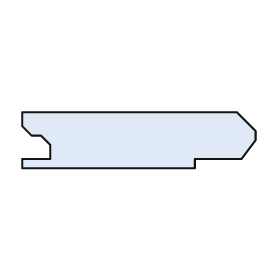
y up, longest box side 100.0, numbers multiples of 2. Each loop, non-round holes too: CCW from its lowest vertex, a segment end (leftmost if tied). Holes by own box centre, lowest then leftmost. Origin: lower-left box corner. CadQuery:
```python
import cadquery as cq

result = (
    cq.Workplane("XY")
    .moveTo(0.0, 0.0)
    .lineTo(74.0, 0.0)
    .lineTo(74.0, 4.0)
    .lineTo(94.0, 4.0)
    .lineTo(100.0, 12.0)
    .lineTo(100.0, 16.0)
    .lineTo(92.0, 24.0)
    .lineTo(0.0, 24.0)
    .lineTo(0.0, 18.0)
    .lineTo(4.0, 14.0)
    .lineTo(8.0, 14.0)
    .lineTo(12.0, 10.0)
    .lineTo(12.0, 4.0)
    .lineTo(0.0, 4.0)
    .close()
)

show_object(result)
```